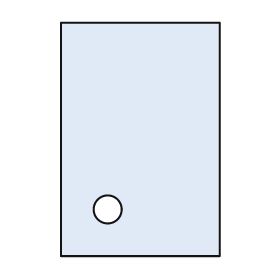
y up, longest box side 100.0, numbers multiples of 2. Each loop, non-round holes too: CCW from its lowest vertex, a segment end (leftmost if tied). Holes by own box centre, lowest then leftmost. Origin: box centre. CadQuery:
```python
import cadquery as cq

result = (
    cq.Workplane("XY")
    .moveTo(-34.0, -50.0)
    .lineTo(34.0, -50.0)
    .lineTo(34.0, 50.0)
    .lineTo(-34.0, 50.0)
    .close()
    .moveTo(-14.0, -30.0)
    .circle(6.0)
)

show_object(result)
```